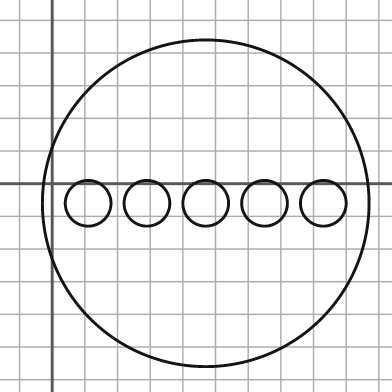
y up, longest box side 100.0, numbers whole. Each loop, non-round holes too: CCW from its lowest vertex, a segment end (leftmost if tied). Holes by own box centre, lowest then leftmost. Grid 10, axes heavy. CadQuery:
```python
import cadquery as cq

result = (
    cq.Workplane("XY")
    .moveTo(47.0, -6.0)
    .circle(50.0)
    .moveTo(11.0, -6.0)
    .circle(7.0)
    .moveTo(29.0, -6.0)
    .circle(7.0)
    .moveTo(47.0, -6.0)
    .circle(7.0)
    .moveTo(65.0, -6.0)
    .circle(7.0)
    .moveTo(83.0, -6.0)
    .circle(7.0)
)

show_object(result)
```